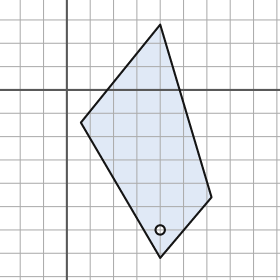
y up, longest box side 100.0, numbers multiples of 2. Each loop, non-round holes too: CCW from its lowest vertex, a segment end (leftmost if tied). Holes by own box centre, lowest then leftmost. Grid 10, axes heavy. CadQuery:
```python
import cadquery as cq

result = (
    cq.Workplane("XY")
    .moveTo(40.0, -72.0)
    .lineTo(62.0, -46.0)
    .lineTo(40.0, 28.0)
    .lineTo(6.0, -14.0)
    .close()
    .moveTo(40.0, -60.0)
    .circle(2.0)
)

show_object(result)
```